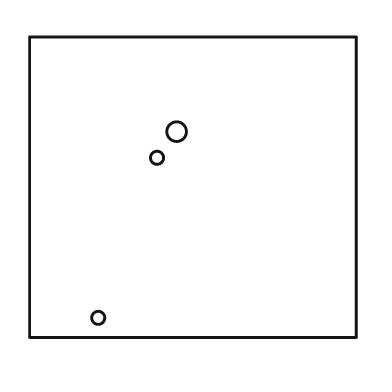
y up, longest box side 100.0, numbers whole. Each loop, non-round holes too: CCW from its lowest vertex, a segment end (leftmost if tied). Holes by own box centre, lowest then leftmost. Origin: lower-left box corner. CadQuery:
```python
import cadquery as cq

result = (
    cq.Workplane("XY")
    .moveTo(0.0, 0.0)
    .lineTo(100.0, 0.0)
    .lineTo(100.0, 92.0)
    .lineTo(0.0, 92.0)
    .close()
    .moveTo(21.0, 6.0)
    .circle(2.0)
    .moveTo(39.0, 55.0)
    .circle(2.0)
    .moveTo(45.0, 63.0)
    .circle(3.0)
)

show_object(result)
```